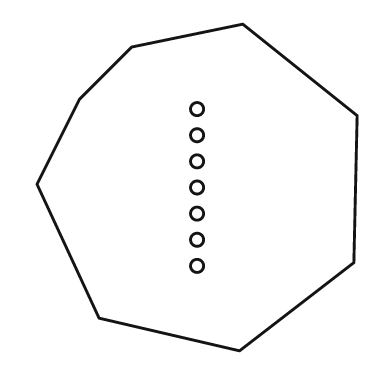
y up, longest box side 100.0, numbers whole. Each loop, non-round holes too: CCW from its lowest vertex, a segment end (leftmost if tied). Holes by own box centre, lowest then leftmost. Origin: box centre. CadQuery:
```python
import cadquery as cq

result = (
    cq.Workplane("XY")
    .moveTo(13.0, -50.0)
    .lineTo(48.0, -23.0)
    .lineTo(49.0, 22.0)
    .lineTo(14.0, 50.0)
    .lineTo(-20.0, 43.0)
    .lineTo(-36.0, 27.0)
    .lineTo(-49.0, 1.0)
    .lineTo(-30.0, -40.0)
    .close()
    .moveTo(0.0, -24.0)
    .circle(2.0)
    .moveTo(0.0, -16.0)
    .circle(2.0)
    .moveTo(0.0, -8.0)
    .circle(2.0)
    .moveTo(0.0, 0.0)
    .circle(2.0)
    .moveTo(0.0, 8.0)
    .circle(2.0)
    .moveTo(0.0, 16.0)
    .circle(2.0)
    .moveTo(0.0, 24.0)
    .circle(2.0)
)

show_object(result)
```